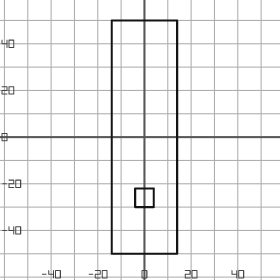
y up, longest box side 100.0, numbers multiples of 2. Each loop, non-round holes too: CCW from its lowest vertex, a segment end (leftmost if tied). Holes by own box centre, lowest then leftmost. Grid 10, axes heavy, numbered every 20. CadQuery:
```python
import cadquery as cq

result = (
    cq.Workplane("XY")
    .moveTo(-14.0, -50.0)
    .lineTo(14.0, -50.0)
    .lineTo(14.0, 50.0)
    .lineTo(-14.0, 50.0)
    .close()
    .moveTo(-4.0, -30.0)
    .lineTo(4.0, -30.0)
    .lineTo(4.0, -22.0)
    .lineTo(-4.0, -22.0)
    .close()
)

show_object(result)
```